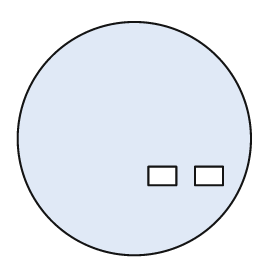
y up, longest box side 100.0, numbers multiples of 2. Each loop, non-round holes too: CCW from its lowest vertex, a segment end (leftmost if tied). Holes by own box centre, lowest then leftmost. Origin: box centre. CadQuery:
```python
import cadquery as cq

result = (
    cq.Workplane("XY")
    .moveTo(0.0, 0.0)
    .circle(50.0)
    .moveTo(6.0, -20.0)
    .lineTo(18.0, -20.0)
    .lineTo(18.0, -12.0)
    .lineTo(6.0, -12.0)
    .close()
    .moveTo(26.0, -20.0)
    .lineTo(38.0, -20.0)
    .lineTo(38.0, -12.0)
    .lineTo(26.0, -12.0)
    .close()
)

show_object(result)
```